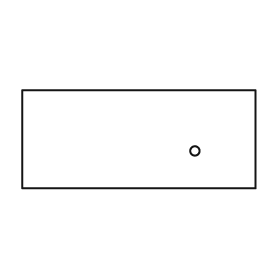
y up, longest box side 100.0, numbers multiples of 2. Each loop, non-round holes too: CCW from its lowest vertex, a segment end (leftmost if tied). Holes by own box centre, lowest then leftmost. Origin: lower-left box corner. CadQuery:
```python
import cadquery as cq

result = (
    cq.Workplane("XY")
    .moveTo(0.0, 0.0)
    .lineTo(100.0, 0.0)
    .lineTo(100.0, 42.0)
    .lineTo(0.0, 42.0)
    .close()
    .moveTo(74.0, 16.0)
    .circle(2.0)
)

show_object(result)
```